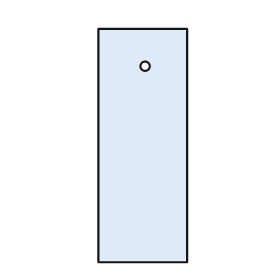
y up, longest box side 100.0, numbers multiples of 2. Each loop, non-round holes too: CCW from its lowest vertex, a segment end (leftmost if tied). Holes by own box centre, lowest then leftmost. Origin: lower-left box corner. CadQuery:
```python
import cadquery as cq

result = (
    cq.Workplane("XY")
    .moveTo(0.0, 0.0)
    .lineTo(38.0, 0.0)
    .lineTo(38.0, 100.0)
    .lineTo(0.0, 100.0)
    .close()
    .moveTo(20.0, 84.0)
    .circle(2.0)
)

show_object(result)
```